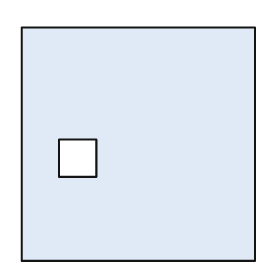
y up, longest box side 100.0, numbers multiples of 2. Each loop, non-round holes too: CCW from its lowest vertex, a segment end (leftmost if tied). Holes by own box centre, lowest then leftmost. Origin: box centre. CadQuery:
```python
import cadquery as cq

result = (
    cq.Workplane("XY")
    .moveTo(-50.0, -50.0)
    .lineTo(50.0, -50.0)
    .lineTo(50.0, 50.0)
    .lineTo(-50.0, 50.0)
    .close()
    .moveTo(-34.0, -14.0)
    .lineTo(-18.0, -14.0)
    .lineTo(-18.0, 2.0)
    .lineTo(-34.0, 2.0)
    .close()
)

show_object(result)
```